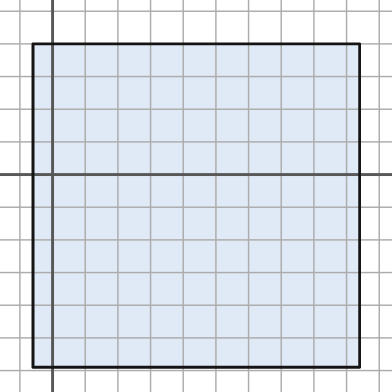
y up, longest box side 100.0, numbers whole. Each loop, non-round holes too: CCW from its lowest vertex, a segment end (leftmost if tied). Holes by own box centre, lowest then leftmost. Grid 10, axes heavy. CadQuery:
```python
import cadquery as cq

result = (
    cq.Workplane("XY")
    .moveTo(-6.0, -59.0)
    .lineTo(94.0, -59.0)
    .lineTo(94.0, 40.0)
    .lineTo(-6.0, 40.0)
    .close()
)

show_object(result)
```